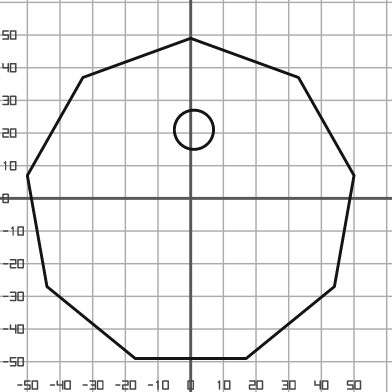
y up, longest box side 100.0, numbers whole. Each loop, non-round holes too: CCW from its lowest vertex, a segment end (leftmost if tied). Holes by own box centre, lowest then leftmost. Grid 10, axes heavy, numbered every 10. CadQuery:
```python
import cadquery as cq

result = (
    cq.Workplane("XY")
    .moveTo(-17.0, -49.0)
    .lineTo(17.0, -49.0)
    .lineTo(44.0, -27.0)
    .lineTo(50.0, 7.0)
    .lineTo(33.0, 37.0)
    .lineTo(0.0, 49.0)
    .lineTo(-33.0, 37.0)
    .lineTo(-50.0, 7.0)
    .lineTo(-44.0, -27.0)
    .close()
    .moveTo(1.0, 21.0)
    .circle(6.0)
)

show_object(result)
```